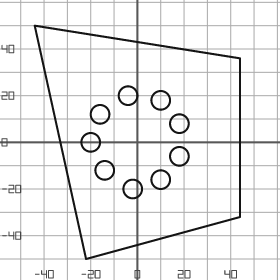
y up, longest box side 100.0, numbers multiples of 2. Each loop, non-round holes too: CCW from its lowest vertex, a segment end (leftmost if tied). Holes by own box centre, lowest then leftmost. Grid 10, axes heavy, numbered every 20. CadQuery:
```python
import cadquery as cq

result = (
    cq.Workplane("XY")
    .moveTo(-22.0, -50.0)
    .lineTo(44.0, -32.0)
    .lineTo(44.0, 36.0)
    .lineTo(-44.0, 50.0)
    .close()
    .moveTo(-2.0, -20.0)
    .circle(4.0)
    .moveTo(10.0, -16.0)
    .circle(4.0)
    .moveTo(-14.0, -12.0)
    .circle(4.0)
    .moveTo(18.0, -6.0)
    .circle(4.0)
    .moveTo(-20.0, 0.0)
    .circle(4.0)
    .moveTo(18.0, 8.0)
    .circle(4.0)
    .moveTo(-16.0, 12.0)
    .circle(4.0)
    .moveTo(10.0, 18.0)
    .circle(4.0)
    .moveTo(-4.0, 20.0)
    .circle(4.0)
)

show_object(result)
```